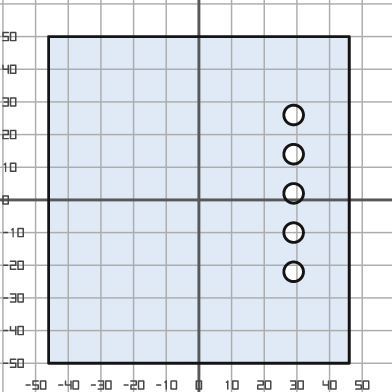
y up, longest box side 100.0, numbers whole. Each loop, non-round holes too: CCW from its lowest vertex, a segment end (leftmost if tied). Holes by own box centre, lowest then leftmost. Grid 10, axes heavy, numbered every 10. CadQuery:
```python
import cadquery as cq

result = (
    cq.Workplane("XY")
    .moveTo(-46.0, -50.0)
    .lineTo(46.0, -50.0)
    .lineTo(46.0, 50.0)
    .lineTo(-46.0, 50.0)
    .close()
    .moveTo(29.0, -22.0)
    .circle(3.0)
    .moveTo(29.0, -10.0)
    .circle(3.0)
    .moveTo(29.0, 2.0)
    .circle(3.0)
    .moveTo(29.0, 14.0)
    .circle(3.0)
    .moveTo(29.0, 26.0)
    .circle(3.0)
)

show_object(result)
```